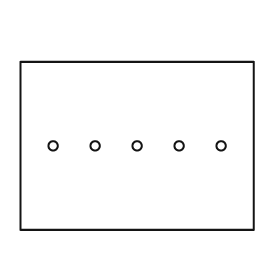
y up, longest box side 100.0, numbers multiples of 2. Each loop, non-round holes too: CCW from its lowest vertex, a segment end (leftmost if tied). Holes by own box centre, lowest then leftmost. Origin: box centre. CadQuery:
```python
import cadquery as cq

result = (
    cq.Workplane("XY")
    .moveTo(-50.0, -36.0)
    .lineTo(50.0, -36.0)
    .lineTo(50.0, 36.0)
    .lineTo(-50.0, 36.0)
    .close()
    .moveTo(-36.0, 0.0)
    .circle(2.0)
    .moveTo(-18.0, 0.0)
    .circle(2.0)
    .moveTo(0.0, 0.0)
    .circle(2.0)
    .moveTo(18.0, 0.0)
    .circle(2.0)
    .moveTo(36.0, 0.0)
    .circle(2.0)
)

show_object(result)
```